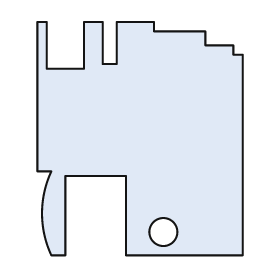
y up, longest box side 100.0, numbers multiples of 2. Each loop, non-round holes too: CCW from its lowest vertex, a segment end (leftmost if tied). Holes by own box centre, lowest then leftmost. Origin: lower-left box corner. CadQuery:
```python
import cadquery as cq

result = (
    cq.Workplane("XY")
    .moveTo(6.0, 0.0)
    .lineTo(12.0, 0.0)
    .lineTo(12.0, 34.0)
    .lineTo(38.0, 34.0)
    .lineTo(38.0, 0.0)
    .lineTo(88.0, 0.0)
    .lineTo(88.0, 86.0)
    .lineTo(84.0, 86.0)
    .lineTo(84.0, 90.0)
    .lineTo(72.0, 90.0)
    .lineTo(72.0, 96.0)
    .lineTo(50.0, 96.0)
    .lineTo(50.0, 100.0)
    .lineTo(34.0, 100.0)
    .lineTo(34.0, 82.0)
    .lineTo(28.0, 82.0)
    .lineTo(28.0, 100.0)
    .lineTo(20.0, 100.0)
    .lineTo(20.0, 80.0)
    .lineTo(4.0, 80.0)
    .lineTo(4.0, 100.0)
    .lineTo(0.0, 100.0)
    .lineTo(0.0, 36.0)
    .lineTo(6.0, 36.0)
    .threePointArc((2.0, 18.0), (6.0, 0.0))
    .close()
    .moveTo(54.0, 10.0)
    .circle(6.0)
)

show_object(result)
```